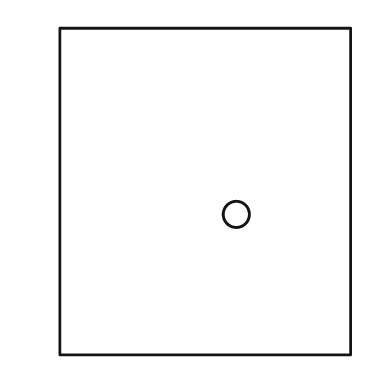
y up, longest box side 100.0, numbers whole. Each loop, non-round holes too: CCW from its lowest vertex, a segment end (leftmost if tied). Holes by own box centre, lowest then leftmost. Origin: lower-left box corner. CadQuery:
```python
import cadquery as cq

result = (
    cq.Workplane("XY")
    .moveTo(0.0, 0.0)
    .lineTo(89.0, 0.0)
    .lineTo(89.0, 100.0)
    .lineTo(0.0, 100.0)
    .close()
    .moveTo(54.0, 43.0)
    .circle(4.0)
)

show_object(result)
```